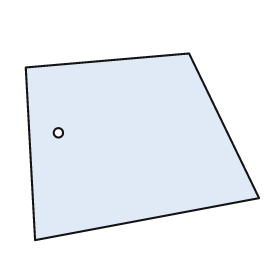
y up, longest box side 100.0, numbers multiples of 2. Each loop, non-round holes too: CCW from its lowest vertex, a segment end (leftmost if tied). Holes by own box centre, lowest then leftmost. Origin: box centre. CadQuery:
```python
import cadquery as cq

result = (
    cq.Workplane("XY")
    .moveTo(-46.0, -40.0)
    .lineTo(50.0, -22.0)
    .lineTo(20.0, 40.0)
    .lineTo(-50.0, 34.0)
    .close()
    .moveTo(-36.0, 6.0)
    .circle(2.0)
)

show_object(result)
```